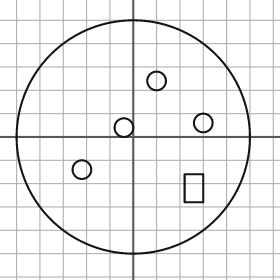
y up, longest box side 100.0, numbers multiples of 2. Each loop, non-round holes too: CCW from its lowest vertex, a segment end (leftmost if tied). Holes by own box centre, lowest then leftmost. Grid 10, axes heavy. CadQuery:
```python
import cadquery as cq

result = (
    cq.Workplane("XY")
    .moveTo(0.0, 0.0)
    .circle(50.0)
    .moveTo(22.0, -28.0)
    .lineTo(30.0, -28.0)
    .lineTo(30.0, -16.0)
    .lineTo(22.0, -16.0)
    .close()
    .moveTo(-22.0, -14.0)
    .circle(4.0)
    .moveTo(-4.0, 4.0)
    .circle(4.0)
    .moveTo(30.0, 6.0)
    .circle(4.0)
    .moveTo(10.0, 24.0)
    .circle(4.0)
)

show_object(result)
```